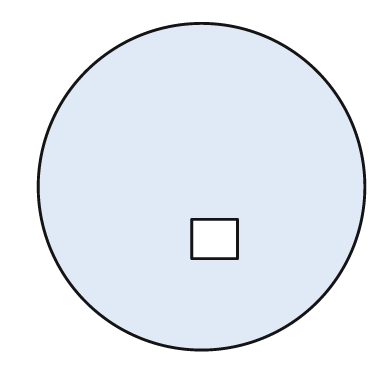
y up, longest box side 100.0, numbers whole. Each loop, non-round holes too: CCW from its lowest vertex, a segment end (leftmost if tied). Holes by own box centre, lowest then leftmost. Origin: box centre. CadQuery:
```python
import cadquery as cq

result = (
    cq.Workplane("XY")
    .moveTo(0.0, 0.0)
    .circle(50.0)
    .moveTo(-3.0, -22.0)
    .lineTo(11.0, -22.0)
    .lineTo(11.0, -10.0)
    .lineTo(-3.0, -10.0)
    .close()
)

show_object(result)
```